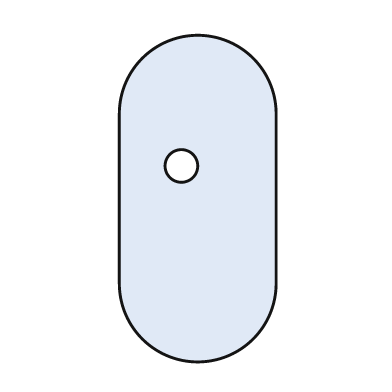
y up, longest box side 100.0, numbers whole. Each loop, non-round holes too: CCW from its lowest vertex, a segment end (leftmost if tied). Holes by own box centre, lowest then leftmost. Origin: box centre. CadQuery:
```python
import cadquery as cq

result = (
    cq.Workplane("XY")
    .moveTo(-24.0, -26.0)
    .threePointArc((0.0, -50.0), (24.0, -26.0))
    .lineTo(24.0, 26.0)
    .threePointArc((0.0, 50.0), (-24.0, 26.0))
    .close()
    .moveTo(-5.0, 10.0)
    .circle(5.0)
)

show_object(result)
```